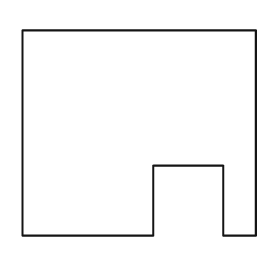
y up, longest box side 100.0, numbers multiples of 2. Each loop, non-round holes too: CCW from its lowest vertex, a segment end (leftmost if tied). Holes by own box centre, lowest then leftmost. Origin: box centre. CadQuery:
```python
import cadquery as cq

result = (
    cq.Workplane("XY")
    .moveTo(-50.0, -44.0)
    .lineTo(6.0, -44.0)
    .lineTo(6.0, -14.0)
    .lineTo(36.0, -14.0)
    .lineTo(36.0, -44.0)
    .lineTo(50.0, -44.0)
    .lineTo(50.0, 44.0)
    .lineTo(-50.0, 44.0)
    .close()
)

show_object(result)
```